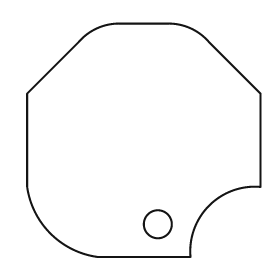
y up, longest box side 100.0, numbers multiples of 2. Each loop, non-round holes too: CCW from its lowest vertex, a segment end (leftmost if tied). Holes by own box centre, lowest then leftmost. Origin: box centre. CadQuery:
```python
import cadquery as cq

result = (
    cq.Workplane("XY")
    .moveTo(-20.0, -50.0)
    .lineTo(20.0, -50.0)
    .threePointArc((28.0, -28.0), (50.0, -20.0))
    .lineTo(50.0, 20.0)
    .lineTo(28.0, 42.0)
    .threePointArc((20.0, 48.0), (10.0, 50.0))
    .lineTo(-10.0, 50.0)
    .threePointArc((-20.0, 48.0), (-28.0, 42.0))
    .lineTo(-50.0, 20.0)
    .lineTo(-50.0, -20.0)
    .threePointArc((-40.0, -40.0), (-20.0, -50.0))
    .close()
    .moveTo(6.0, -36.0)
    .circle(6.0)
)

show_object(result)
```